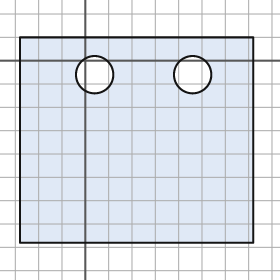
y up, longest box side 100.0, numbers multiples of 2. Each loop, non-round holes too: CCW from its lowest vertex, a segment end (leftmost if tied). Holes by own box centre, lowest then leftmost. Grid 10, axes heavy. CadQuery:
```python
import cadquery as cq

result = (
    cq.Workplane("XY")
    .moveTo(-28.0, -78.0)
    .lineTo(72.0, -78.0)
    .lineTo(72.0, 10.0)
    .lineTo(-28.0, 10.0)
    .close()
    .moveTo(4.0, -6.0)
    .circle(8.0)
    .moveTo(46.0, -6.0)
    .circle(8.0)
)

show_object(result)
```